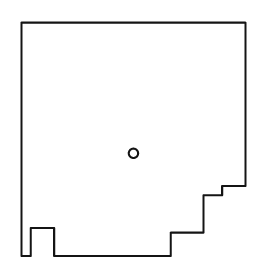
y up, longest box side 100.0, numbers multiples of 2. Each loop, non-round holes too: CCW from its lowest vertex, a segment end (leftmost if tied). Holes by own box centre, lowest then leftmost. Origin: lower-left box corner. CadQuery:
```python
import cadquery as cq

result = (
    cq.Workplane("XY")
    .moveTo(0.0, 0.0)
    .lineTo(4.0, 0.0)
    .lineTo(4.0, 12.0)
    .lineTo(14.0, 12.0)
    .lineTo(14.0, 0.0)
    .lineTo(64.0, 0.0)
    .lineTo(64.0, 10.0)
    .lineTo(78.0, 10.0)
    .lineTo(78.0, 26.0)
    .lineTo(86.0, 26.0)
    .lineTo(86.0, 30.0)
    .lineTo(96.0, 30.0)
    .lineTo(96.0, 100.0)
    .lineTo(0.0, 100.0)
    .close()
    .moveTo(48.0, 44.0)
    .circle(2.0)
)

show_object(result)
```